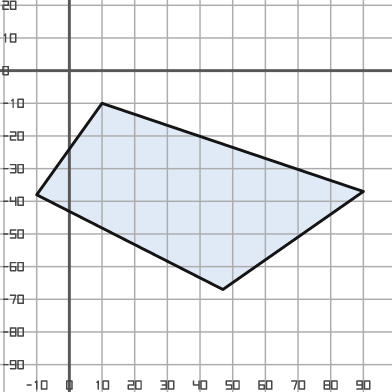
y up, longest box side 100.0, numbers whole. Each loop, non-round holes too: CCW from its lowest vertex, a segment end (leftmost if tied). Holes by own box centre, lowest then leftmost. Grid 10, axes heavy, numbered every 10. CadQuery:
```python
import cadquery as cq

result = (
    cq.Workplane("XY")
    .moveTo(47.0, -67.0)
    .lineTo(90.0, -37.0)
    .lineTo(10.0, -10.0)
    .lineTo(-10.0, -38.0)
    .close()
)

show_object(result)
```